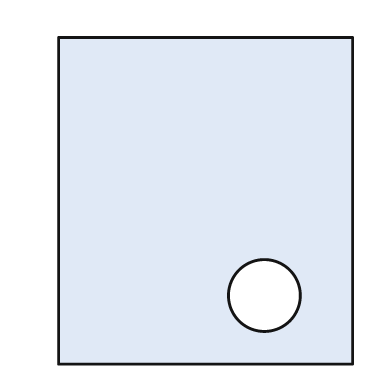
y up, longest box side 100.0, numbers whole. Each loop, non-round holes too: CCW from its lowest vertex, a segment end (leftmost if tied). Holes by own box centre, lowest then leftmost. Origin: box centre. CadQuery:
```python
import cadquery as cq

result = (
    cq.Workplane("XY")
    .moveTo(-45.0, -50.0)
    .lineTo(45.0, -50.0)
    .lineTo(45.0, 50.0)
    .lineTo(-45.0, 50.0)
    .close()
    .moveTo(18.0, -29.0)
    .circle(11.0)
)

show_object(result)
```